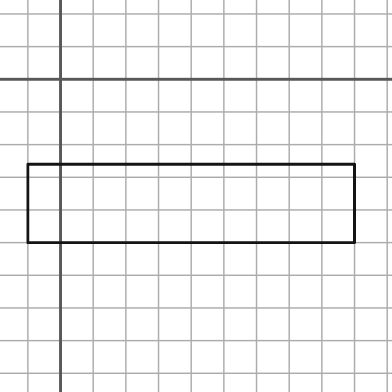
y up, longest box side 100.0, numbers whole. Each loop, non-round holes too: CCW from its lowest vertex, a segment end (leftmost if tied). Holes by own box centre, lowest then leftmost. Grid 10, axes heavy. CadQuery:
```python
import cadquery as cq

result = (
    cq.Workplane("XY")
    .moveTo(-10.0, -50.0)
    .lineTo(90.0, -50.0)
    .lineTo(90.0, -26.0)
    .lineTo(-10.0, -26.0)
    .close()
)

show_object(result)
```